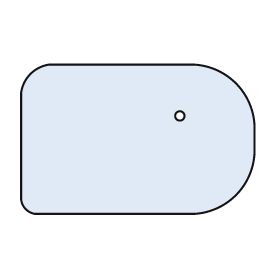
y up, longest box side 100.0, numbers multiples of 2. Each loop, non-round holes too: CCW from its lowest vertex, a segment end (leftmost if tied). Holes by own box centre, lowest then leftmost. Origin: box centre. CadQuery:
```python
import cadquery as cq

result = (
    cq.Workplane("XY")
    .moveTo(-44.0, -32.0)
    .lineTo(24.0, -32.0)
    .threePointArc((42.0, -24.0), (50.0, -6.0))
    .lineTo(50.0, 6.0)
    .threePointArc((42.0, 24.0), (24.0, 32.0))
    .lineTo(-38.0, 32.0)
    .threePointArc((-46.0, 28.0), (-50.0, 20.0))
    .lineTo(-50.0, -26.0)
    .threePointArc((-48.0, -30.0), (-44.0, -32.0))
    .close()
    .moveTo(18.0, 10.0)
    .circle(2.0)
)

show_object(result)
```